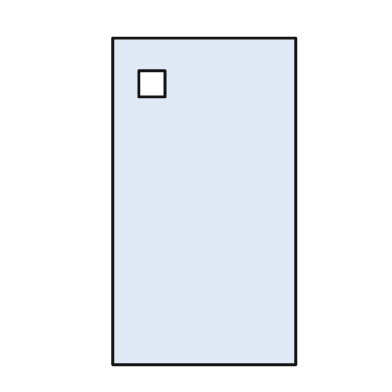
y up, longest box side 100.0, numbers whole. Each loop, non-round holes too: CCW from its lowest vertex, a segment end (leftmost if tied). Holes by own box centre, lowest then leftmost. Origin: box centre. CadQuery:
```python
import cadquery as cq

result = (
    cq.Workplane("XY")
    .moveTo(-28.0, -50.0)
    .lineTo(28.0, -50.0)
    .lineTo(28.0, 50.0)
    .lineTo(-28.0, 50.0)
    .close()
    .moveTo(-20.0, 32.0)
    .lineTo(-12.0, 32.0)
    .lineTo(-12.0, 40.0)
    .lineTo(-20.0, 40.0)
    .close()
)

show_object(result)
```